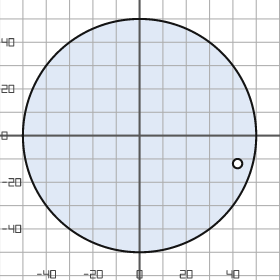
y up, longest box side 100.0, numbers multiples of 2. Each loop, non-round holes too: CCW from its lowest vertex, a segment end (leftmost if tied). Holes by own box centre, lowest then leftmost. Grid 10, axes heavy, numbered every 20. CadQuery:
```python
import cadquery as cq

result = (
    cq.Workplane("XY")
    .moveTo(0.0, 0.0)
    .circle(50.0)
    .moveTo(42.0, -12.0)
    .circle(2.0)
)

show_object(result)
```